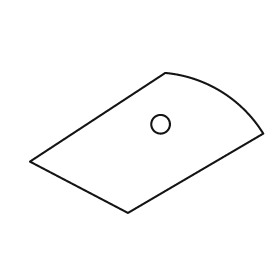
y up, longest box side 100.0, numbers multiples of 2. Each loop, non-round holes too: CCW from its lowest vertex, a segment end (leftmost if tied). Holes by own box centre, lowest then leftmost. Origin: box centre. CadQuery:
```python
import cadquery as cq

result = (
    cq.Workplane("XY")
    .moveTo(-8.0, -30.0)
    .lineTo(50.0, 4.0)
    .threePointArc((32.0, 22.0), (8.0, 30.0))
    .lineTo(-50.0, -8.0)
    .close()
    .moveTo(6.0, 8.0)
    .circle(4.0)
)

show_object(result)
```